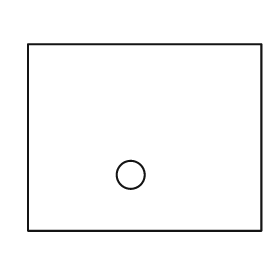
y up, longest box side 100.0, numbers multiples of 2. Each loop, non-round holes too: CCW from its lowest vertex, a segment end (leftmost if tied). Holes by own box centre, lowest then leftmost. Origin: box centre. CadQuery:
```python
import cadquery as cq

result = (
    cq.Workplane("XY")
    .moveTo(-50.0, -40.0)
    .lineTo(50.0, -40.0)
    .lineTo(50.0, 40.0)
    .lineTo(-50.0, 40.0)
    .close()
    .moveTo(-6.0, -16.0)
    .circle(6.0)
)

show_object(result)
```